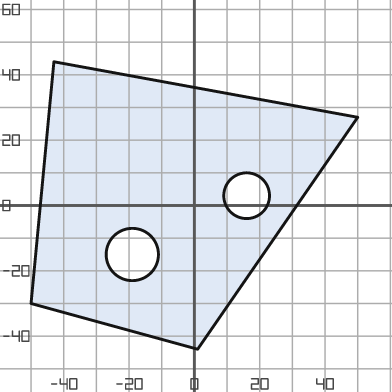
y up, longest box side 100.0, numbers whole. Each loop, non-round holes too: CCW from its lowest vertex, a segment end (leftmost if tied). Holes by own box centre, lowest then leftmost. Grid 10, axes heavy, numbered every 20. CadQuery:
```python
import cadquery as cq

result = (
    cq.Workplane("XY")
    .moveTo(1.0, -44.0)
    .lineTo(50.0, 27.0)
    .lineTo(-43.0, 44.0)
    .lineTo(-50.0, -30.0)
    .close()
    .moveTo(-19.0, -15.0)
    .circle(8.0)
    .moveTo(16.0, 3.0)
    .circle(7.0)
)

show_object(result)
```